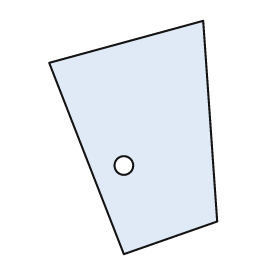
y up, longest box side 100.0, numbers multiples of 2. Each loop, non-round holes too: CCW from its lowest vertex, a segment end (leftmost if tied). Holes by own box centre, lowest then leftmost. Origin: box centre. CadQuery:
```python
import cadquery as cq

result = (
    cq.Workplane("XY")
    .moveTo(-4.0, -50.0)
    .lineTo(36.0, -36.0)
    .lineTo(30.0, 50.0)
    .lineTo(-36.0, 32.0)
    .close()
    .moveTo(-4.0, -12.0)
    .circle(4.0)
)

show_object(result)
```